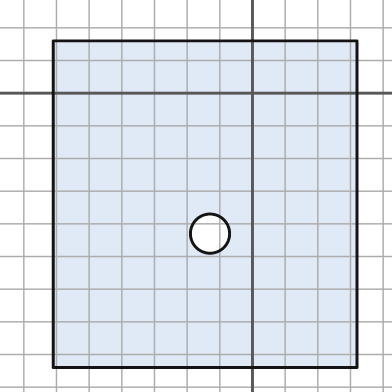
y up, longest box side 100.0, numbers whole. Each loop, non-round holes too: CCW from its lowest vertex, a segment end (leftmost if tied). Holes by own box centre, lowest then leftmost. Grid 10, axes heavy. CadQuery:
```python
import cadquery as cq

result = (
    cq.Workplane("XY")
    .moveTo(-61.0, -84.0)
    .lineTo(32.0, -84.0)
    .lineTo(32.0, 16.0)
    .lineTo(-61.0, 16.0)
    .close()
    .moveTo(-13.0, -43.0)
    .circle(6.0)
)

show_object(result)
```